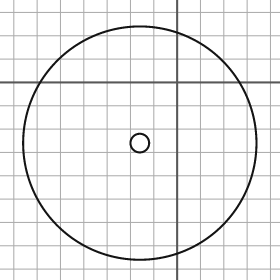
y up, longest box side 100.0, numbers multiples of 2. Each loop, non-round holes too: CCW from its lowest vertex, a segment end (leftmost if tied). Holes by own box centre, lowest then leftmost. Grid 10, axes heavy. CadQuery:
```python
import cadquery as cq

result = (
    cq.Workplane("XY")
    .moveTo(-16.0, -26.0)
    .circle(50.0)
    .moveTo(-16.0, -26.0)
    .circle(4.0)
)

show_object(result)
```